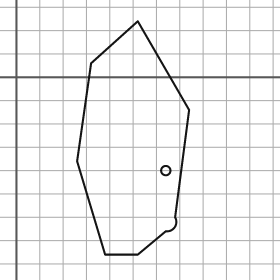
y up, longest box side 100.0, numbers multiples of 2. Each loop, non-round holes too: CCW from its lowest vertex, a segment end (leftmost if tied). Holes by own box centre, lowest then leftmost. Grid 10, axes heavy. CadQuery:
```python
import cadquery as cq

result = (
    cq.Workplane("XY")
    .moveTo(38.0, -76.0)
    .lineTo(52.0, -76.0)
    .lineTo(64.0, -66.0)
    .threePointArc((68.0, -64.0), (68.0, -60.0))
    .lineTo(74.0, -14.0)
    .lineTo(52.0, 24.0)
    .lineTo(32.0, 6.0)
    .lineTo(26.0, -36.0)
    .close()
    .moveTo(64.0, -40.0)
    .circle(2.0)
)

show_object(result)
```